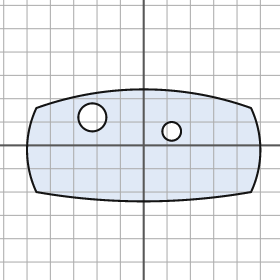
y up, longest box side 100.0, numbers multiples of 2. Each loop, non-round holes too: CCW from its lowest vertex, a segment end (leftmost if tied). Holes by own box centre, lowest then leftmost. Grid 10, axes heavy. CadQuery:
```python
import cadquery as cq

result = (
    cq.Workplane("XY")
    .moveTo(-46.0, -20.0)
    .threePointArc((0.0, -24.0), (46.0, -20.0))
    .threePointArc((50.0, -2.0), (46.0, 16.0))
    .threePointArc((0.0, 24.0), (-46.0, 16.0))
    .threePointArc((-50.0, -2.0), (-46.0, -20.0))
    .close()
    .moveTo(12.0, 6.0)
    .circle(4.0)
    .moveTo(-22.0, 12.0)
    .circle(6.0)
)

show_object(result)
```